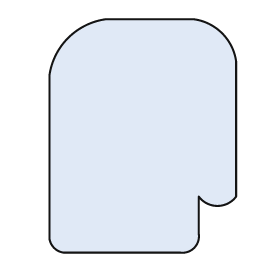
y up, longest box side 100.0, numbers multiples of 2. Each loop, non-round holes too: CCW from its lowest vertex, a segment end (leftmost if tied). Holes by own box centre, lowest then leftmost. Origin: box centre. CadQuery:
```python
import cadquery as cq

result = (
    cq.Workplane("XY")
    .moveTo(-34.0, -50.0)
    .lineTo(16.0, -50.0)
    .threePointArc((22.0, -48.0), (24.0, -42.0))
    .lineTo(24.0, -26.0)
    .threePointArc((32.0, -30.0), (40.0, -26.0))
    .lineTo(40.0, 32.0)
    .threePointArc((34.0, 44.0), (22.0, 50.0))
    .lineTo(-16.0, 50.0)
    .threePointArc((-32.0, 42.0), (-40.0, 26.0))
    .lineTo(-40.0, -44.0)
    .threePointArc((-38.0, -48.0), (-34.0, -50.0))
    .close()
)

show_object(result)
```